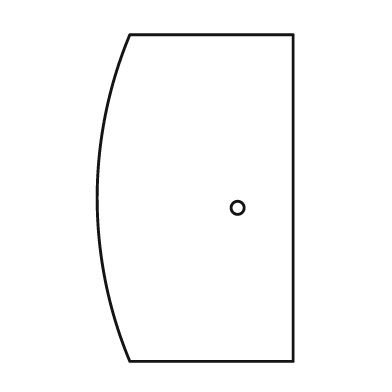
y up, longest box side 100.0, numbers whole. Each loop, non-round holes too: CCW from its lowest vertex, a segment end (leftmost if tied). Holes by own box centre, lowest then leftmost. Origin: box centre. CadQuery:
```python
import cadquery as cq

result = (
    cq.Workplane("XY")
    .moveTo(-20.0, -50.0)
    .lineTo(30.0, -50.0)
    .lineTo(30.0, 50.0)
    .lineTo(-20.0, 50.0)
    .threePointArc((-30.0, 0.0), (-20.0, -50.0))
    .close()
    .moveTo(13.0, -3.0)
    .circle(2.0)
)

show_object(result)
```